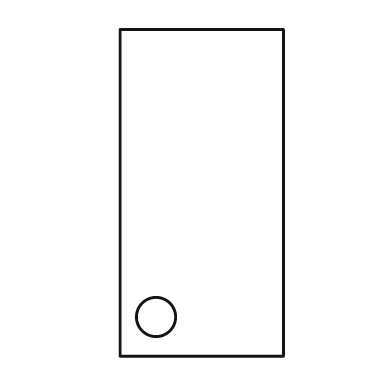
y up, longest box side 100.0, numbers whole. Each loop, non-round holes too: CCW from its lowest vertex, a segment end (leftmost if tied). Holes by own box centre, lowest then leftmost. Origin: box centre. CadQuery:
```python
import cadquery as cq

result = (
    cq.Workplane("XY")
    .moveTo(-25.0, -50.0)
    .lineTo(25.0, -50.0)
    .lineTo(25.0, 50.0)
    .lineTo(-25.0, 50.0)
    .close()
    .moveTo(-14.0, -38.0)
    .circle(6.0)
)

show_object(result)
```